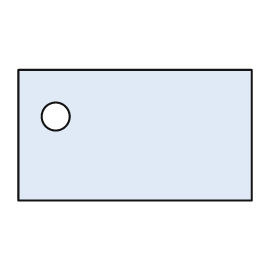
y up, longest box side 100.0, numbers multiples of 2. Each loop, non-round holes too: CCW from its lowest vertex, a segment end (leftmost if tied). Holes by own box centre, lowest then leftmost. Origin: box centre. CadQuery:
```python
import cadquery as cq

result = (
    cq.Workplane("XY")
    .moveTo(-50.0, -28.0)
    .lineTo(50.0, -28.0)
    .lineTo(50.0, 28.0)
    .lineTo(-50.0, 28.0)
    .close()
    .moveTo(-34.0, 8.0)
    .circle(6.0)
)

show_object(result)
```